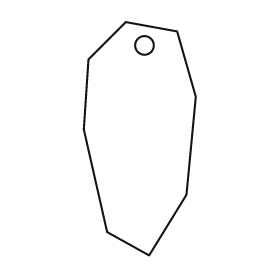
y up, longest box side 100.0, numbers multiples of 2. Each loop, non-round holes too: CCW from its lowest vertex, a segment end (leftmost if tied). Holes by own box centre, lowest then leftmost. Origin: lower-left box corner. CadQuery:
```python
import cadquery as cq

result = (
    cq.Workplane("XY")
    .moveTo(28.0, 0.0)
    .lineTo(44.0, 26.0)
    .lineTo(48.0, 68.0)
    .lineTo(40.0, 96.0)
    .lineTo(18.0, 100.0)
    .lineTo(2.0, 84.0)
    .lineTo(0.0, 54.0)
    .lineTo(10.0, 10.0)
    .close()
    .moveTo(26.0, 90.0)
    .circle(4.0)
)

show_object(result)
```